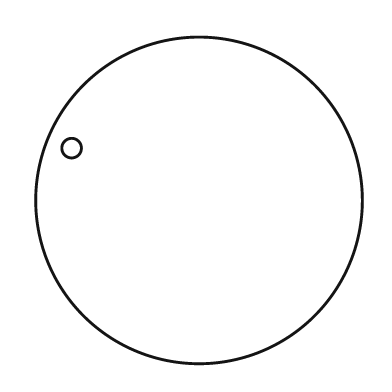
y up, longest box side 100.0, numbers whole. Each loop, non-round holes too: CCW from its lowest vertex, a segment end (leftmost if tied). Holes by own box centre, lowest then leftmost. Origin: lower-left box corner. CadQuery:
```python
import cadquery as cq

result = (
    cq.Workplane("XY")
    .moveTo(50.0, 50.0)
    .circle(50.0)
    .moveTo(11.0, 66.0)
    .circle(3.0)
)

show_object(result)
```